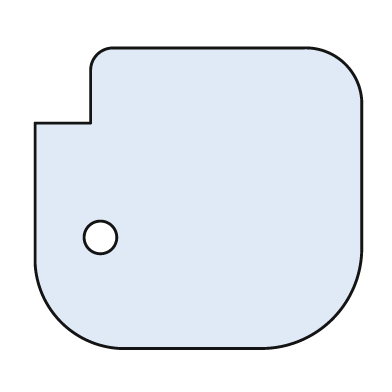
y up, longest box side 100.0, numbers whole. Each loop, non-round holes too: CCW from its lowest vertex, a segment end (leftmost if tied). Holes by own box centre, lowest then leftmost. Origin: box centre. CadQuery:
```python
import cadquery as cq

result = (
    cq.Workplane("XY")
    .moveTo(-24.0, -46.0)
    .lineTo(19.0, -46.0)
    .threePointArc((41.0, -37.0), (50.0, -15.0))
    .lineTo(50.0, 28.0)
    .threePointArc((45.0, 41.0), (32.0, 46.0))
    .lineTo(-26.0, 46.0)
    .threePointArc((-31.0, 44.0), (-33.0, 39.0))
    .lineTo(-33.0, 23.0)
    .lineTo(-50.0, 23.0)
    .lineTo(-50.0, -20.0)
    .threePointArc((-42.0, -38.0), (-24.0, -46.0))
    .close()
    .moveTo(-30.0, -12.0)
    .circle(5.0)
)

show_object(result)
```